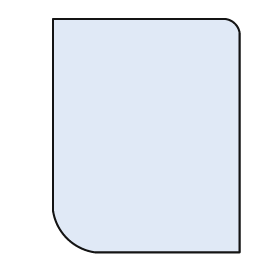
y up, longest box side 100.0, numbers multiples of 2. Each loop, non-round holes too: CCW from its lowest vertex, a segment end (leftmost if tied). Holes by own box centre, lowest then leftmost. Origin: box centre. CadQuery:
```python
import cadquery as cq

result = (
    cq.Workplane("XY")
    .moveTo(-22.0, -50.0)
    .lineTo(40.0, -50.0)
    .lineTo(40.0, 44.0)
    .threePointArc((38.0, 48.0), (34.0, 50.0))
    .lineTo(-40.0, 50.0)
    .lineTo(-40.0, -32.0)
    .threePointArc((-34.0, -44.0), (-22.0, -50.0))
    .close()
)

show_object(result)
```